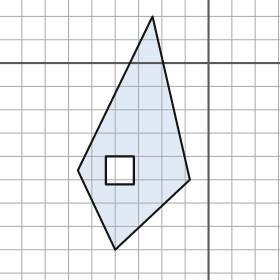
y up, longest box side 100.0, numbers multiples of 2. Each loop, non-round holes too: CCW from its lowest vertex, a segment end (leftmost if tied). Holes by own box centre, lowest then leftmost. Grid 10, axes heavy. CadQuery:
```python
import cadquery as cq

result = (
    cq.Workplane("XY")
    .moveTo(-40.0, -80.0)
    .lineTo(-8.0, -50.0)
    .lineTo(-24.0, 20.0)
    .lineTo(-56.0, -46.0)
    .close()
    .moveTo(-44.0, -52.0)
    .lineTo(-32.0, -52.0)
    .lineTo(-32.0, -40.0)
    .lineTo(-44.0, -40.0)
    .close()
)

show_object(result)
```